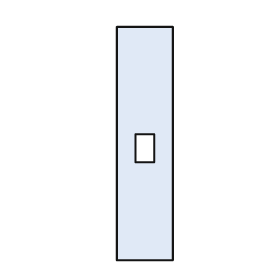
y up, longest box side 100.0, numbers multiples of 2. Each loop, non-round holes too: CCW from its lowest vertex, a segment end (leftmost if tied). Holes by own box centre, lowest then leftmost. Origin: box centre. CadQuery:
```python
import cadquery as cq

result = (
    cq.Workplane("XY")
    .moveTo(-12.0, -50.0)
    .lineTo(12.0, -50.0)
    .lineTo(12.0, 50.0)
    .lineTo(-12.0, 50.0)
    .close()
    .moveTo(-4.0, -8.0)
    .lineTo(4.0, -8.0)
    .lineTo(4.0, 4.0)
    .lineTo(-4.0, 4.0)
    .close()
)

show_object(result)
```